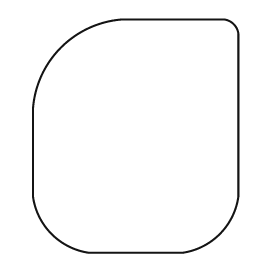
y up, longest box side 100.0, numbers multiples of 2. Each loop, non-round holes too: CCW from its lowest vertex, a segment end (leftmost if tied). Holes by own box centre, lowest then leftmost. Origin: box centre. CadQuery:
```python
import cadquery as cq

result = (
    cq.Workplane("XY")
    .moveTo(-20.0, -50.0)
    .lineTo(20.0, -50.0)
    .threePointArc((36.0, -42.0), (44.0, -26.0))
    .lineTo(44.0, 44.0)
    .threePointArc((42.0, 48.0), (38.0, 50.0))
    .lineTo(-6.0, 50.0)
    .threePointArc((-32.0, 38.0), (-44.0, 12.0))
    .lineTo(-44.0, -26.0)
    .threePointArc((-36.0, -42.0), (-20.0, -50.0))
    .close()
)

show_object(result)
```